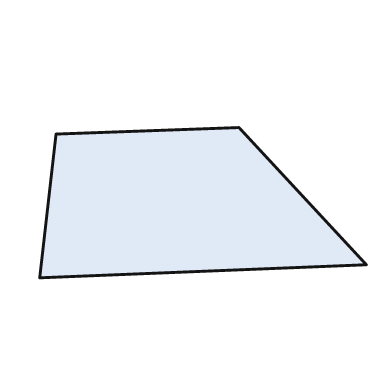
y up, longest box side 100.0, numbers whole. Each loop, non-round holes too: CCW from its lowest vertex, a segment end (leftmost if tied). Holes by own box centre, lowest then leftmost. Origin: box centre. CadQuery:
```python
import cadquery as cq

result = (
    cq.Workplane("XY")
    .moveTo(-50.0, -23.0)
    .lineTo(50.0, -19.0)
    .lineTo(11.0, 23.0)
    .lineTo(-45.0, 21.0)
    .close()
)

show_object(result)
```